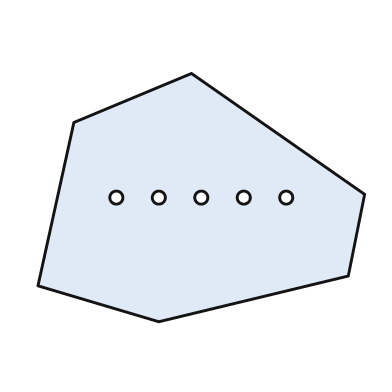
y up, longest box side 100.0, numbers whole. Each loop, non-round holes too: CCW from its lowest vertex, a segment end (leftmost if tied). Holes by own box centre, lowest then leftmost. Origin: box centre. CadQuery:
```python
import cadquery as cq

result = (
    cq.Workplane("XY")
    .moveTo(-13.0, -38.0)
    .lineTo(45.0, -24.0)
    .lineTo(50.0, 1.0)
    .lineTo(-3.0, 38.0)
    .lineTo(-39.0, 23.0)
    .lineTo(-50.0, -27.0)
    .close()
    .moveTo(-26.0, 0.0)
    .circle(2.0)
    .moveTo(-13.0, 0.0)
    .circle(2.0)
    .moveTo(0.0, 0.0)
    .circle(2.0)
    .moveTo(13.0, 0.0)
    .circle(2.0)
    .moveTo(26.0, 0.0)
    .circle(2.0)
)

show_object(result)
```